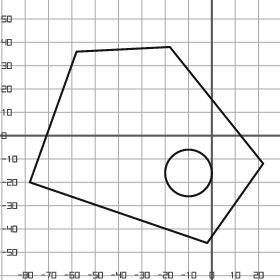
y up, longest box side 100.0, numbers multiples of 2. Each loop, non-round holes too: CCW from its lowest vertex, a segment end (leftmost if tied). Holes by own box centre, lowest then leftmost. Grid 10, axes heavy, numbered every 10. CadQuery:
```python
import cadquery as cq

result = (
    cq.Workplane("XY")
    .moveTo(-2.0, -46.0)
    .lineTo(22.0, -12.0)
    .lineTo(-18.0, 38.0)
    .lineTo(-58.0, 36.0)
    .lineTo(-78.0, -20.0)
    .close()
    .moveTo(-10.0, -16.0)
    .circle(10.0)
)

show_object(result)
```